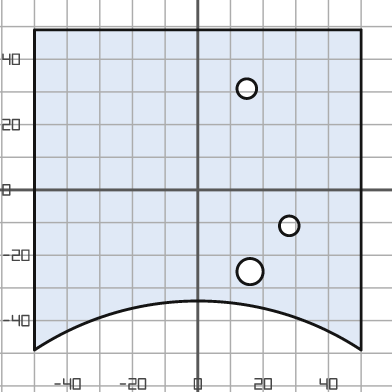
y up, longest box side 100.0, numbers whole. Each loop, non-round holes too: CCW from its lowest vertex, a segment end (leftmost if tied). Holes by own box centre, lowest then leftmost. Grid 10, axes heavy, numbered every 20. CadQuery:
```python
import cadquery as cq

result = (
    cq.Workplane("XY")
    .moveTo(-50.0, -49.0)
    .threePointArc((0.0, -34.0), (50.0, -49.0))
    .lineTo(50.0, 49.0)
    .lineTo(-50.0, 49.0)
    .close()
    .moveTo(16.0, -25.0)
    .circle(4.0)
    .moveTo(28.0, -11.0)
    .circle(3.0)
    .moveTo(15.0, 31.0)
    .circle(3.0)
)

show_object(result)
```